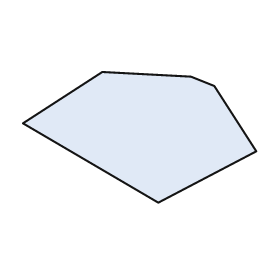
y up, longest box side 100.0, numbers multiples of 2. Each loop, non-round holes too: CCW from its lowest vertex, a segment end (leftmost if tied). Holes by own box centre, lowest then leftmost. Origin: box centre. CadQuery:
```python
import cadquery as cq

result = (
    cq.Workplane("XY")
    .moveTo(8.0, -28.0)
    .lineTo(50.0, -6.0)
    .lineTo(32.0, 22.0)
    .lineTo(22.0, 26.0)
    .lineTo(-16.0, 28.0)
    .lineTo(-50.0, 6.0)
    .close()
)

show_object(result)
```